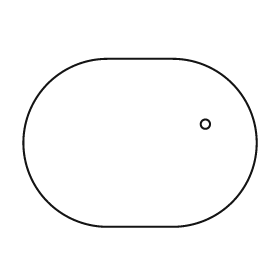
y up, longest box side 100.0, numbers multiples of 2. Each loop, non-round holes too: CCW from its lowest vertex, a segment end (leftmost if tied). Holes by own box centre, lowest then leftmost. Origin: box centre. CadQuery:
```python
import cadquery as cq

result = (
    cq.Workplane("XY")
    .moveTo(-14.0, -36.0)
    .lineTo(14.0, -36.0)
    .threePointArc((50.0, 0.0), (14.0, 36.0))
    .lineTo(-14.0, 36.0)
    .threePointArc((-50.0, 0.0), (-14.0, -36.0))
    .close()
    .moveTo(28.0, 8.0)
    .circle(2.0)
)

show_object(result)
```